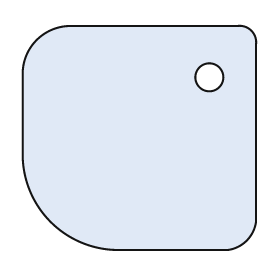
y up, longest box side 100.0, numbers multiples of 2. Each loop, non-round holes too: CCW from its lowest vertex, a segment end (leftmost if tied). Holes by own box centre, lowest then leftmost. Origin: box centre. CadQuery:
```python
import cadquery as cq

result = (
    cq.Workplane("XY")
    .moveTo(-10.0, -48.0)
    .lineTo(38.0, -48.0)
    .threePointArc((46.0, -44.0), (50.0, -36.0))
    .lineTo(50.0, 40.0)
    .threePointArc((48.0, 46.0), (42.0, 48.0))
    .lineTo(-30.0, 48.0)
    .threePointArc((-44.0, 42.0), (-50.0, 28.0))
    .lineTo(-50.0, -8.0)
    .threePointArc((-38.0, -36.0), (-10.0, -48.0))
    .close()
    .moveTo(30.0, 26.0)
    .circle(6.0)
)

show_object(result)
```